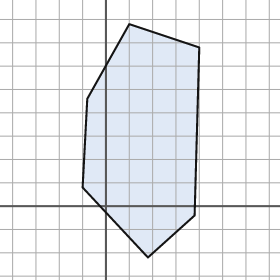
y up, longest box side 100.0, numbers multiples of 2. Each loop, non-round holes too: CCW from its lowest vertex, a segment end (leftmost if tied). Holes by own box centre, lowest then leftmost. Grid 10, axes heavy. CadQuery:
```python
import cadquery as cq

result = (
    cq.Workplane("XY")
    .moveTo(18.0, -22.0)
    .lineTo(38.0, -4.0)
    .lineTo(40.0, 68.0)
    .lineTo(10.0, 78.0)
    .lineTo(-8.0, 46.0)
    .lineTo(-10.0, 8.0)
    .close()
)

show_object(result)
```